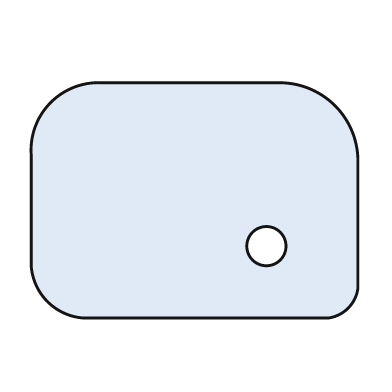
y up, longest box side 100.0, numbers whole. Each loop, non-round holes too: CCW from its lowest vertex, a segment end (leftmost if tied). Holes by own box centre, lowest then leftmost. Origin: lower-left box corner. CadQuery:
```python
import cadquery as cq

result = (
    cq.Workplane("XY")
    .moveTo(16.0, 0.0)
    .lineTo(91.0, 0.0)
    .threePointArc((97.0, 3.0), (100.0, 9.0))
    .lineTo(100.0, 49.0)
    .threePointArc((93.0, 65.0), (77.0, 72.0))
    .lineTo(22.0, 72.0)
    .threePointArc((6.0, 66.0), (0.0, 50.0))
    .lineTo(0.0, 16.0)
    .threePointArc((5.0, 5.0), (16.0, 0.0))
    .close()
    .moveTo(72.0, 22.0)
    .circle(6.0)
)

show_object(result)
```